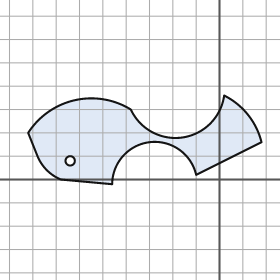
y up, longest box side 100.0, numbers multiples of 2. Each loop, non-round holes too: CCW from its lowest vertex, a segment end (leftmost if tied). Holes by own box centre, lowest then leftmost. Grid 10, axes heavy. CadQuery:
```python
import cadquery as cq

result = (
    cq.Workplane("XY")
    .moveTo(-46.0, -2.0)
    .threePointArc((-30.0, 16.0), (-10.0, 2.0))
    .lineTo(18.0, 16.0)
    .threePointArc((12.0, 28.0), (2.0, 36.0))
    .threePointArc((-16.0, 18.0), (-38.0, 30.0))
    .threePointArc((-62.0, 34.0), (-82.0, 20.0))
    .lineTo(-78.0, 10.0)
    .threePointArc((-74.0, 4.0), (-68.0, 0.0))
    .close()
    .moveTo(-64.0, 8.0)
    .circle(2.0)
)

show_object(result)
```